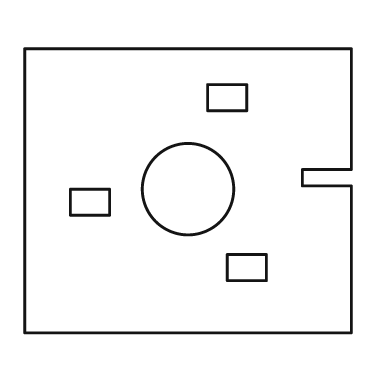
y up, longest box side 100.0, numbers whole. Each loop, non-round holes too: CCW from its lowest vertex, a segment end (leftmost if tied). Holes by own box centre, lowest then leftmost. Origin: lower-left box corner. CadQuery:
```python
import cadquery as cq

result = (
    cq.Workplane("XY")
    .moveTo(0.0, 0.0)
    .lineTo(100.0, 0.0)
    .lineTo(100.0, 45.0)
    .lineTo(85.0, 45.0)
    .lineTo(85.0, 50.0)
    .lineTo(100.0, 50.0)
    .lineTo(100.0, 87.0)
    .lineTo(0.0, 87.0)
    .close()
    .moveTo(62.0, 16.0)
    .lineTo(74.0, 16.0)
    .lineTo(74.0, 24.0)
    .lineTo(62.0, 24.0)
    .close()
    .moveTo(14.0, 36.0)
    .lineTo(26.0, 36.0)
    .lineTo(26.0, 44.0)
    .lineTo(14.0, 44.0)
    .close()
    .moveTo(50.0, 44.0)
    .circle(14.0)
    .moveTo(56.0, 68.0)
    .lineTo(68.0, 68.0)
    .lineTo(68.0, 76.0)
    .lineTo(56.0, 76.0)
    .close()
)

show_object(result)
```